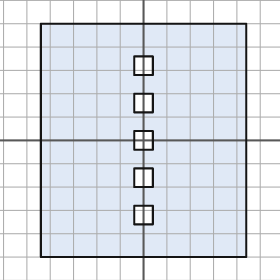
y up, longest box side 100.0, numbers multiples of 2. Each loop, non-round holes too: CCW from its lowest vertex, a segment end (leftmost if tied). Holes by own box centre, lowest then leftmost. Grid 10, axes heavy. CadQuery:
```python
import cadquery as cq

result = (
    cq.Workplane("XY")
    .moveTo(-44.0, -50.0)
    .lineTo(44.0, -50.0)
    .lineTo(44.0, 50.0)
    .lineTo(-44.0, 50.0)
    .close()
    .moveTo(-4.0, -36.0)
    .lineTo(4.0, -36.0)
    .lineTo(4.0, -28.0)
    .lineTo(-4.0, -28.0)
    .close()
    .moveTo(-4.0, -20.0)
    .lineTo(4.0, -20.0)
    .lineTo(4.0, -12.0)
    .lineTo(-4.0, -12.0)
    .close()
    .moveTo(-4.0, -4.0)
    .lineTo(4.0, -4.0)
    .lineTo(4.0, 4.0)
    .lineTo(-4.0, 4.0)
    .close()
    .moveTo(-4.0, 12.0)
    .lineTo(4.0, 12.0)
    .lineTo(4.0, 20.0)
    .lineTo(-4.0, 20.0)
    .close()
    .moveTo(-4.0, 28.0)
    .lineTo(4.0, 28.0)
    .lineTo(4.0, 36.0)
    .lineTo(-4.0, 36.0)
    .close()
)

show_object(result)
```